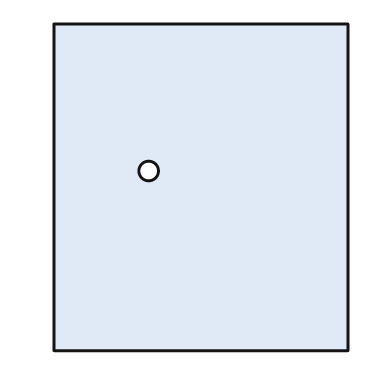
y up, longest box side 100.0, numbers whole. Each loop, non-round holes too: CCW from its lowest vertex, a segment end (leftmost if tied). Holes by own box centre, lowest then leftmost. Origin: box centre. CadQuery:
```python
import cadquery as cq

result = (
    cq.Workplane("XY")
    .moveTo(-45.0, -50.0)
    .lineTo(45.0, -50.0)
    .lineTo(45.0, 50.0)
    .lineTo(-45.0, 50.0)
    .close()
    .moveTo(-16.0, 5.0)
    .circle(3.0)
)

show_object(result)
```